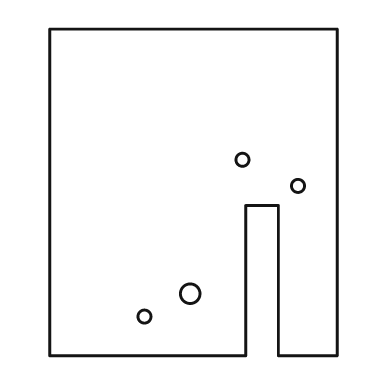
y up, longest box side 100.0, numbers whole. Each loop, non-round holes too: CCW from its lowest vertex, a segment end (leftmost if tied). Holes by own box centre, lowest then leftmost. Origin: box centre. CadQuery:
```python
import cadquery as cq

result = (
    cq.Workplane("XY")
    .moveTo(-44.0, -50.0)
    .lineTo(16.0, -50.0)
    .lineTo(16.0, -4.0)
    .lineTo(26.0, -4.0)
    .lineTo(26.0, -50.0)
    .lineTo(44.0, -50.0)
    .lineTo(44.0, 50.0)
    .lineTo(-44.0, 50.0)
    .close()
    .moveTo(-15.0, -38.0)
    .circle(2.0)
    .moveTo(-1.0, -31.0)
    .circle(3.0)
    .moveTo(32.0, 2.0)
    .circle(2.0)
    .moveTo(15.0, 10.0)
    .circle(2.0)
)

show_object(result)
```